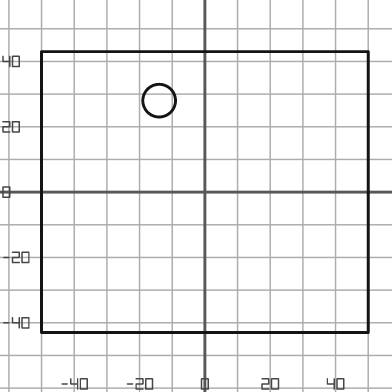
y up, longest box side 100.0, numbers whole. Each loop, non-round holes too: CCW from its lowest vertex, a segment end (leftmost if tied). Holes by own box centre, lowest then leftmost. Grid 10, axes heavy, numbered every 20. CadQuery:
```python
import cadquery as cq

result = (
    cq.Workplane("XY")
    .moveTo(-50.0, -43.0)
    .lineTo(50.0, -43.0)
    .lineTo(50.0, 43.0)
    .lineTo(-50.0, 43.0)
    .close()
    .moveTo(-14.0, 28.0)
    .circle(5.0)
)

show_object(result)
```